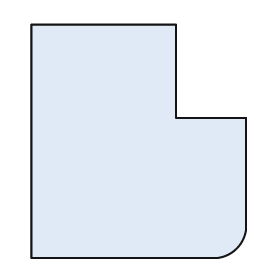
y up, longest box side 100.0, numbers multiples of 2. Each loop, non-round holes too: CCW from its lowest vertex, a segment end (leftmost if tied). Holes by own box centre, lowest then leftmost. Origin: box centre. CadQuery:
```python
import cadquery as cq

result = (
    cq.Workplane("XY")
    .moveTo(-46.0, -50.0)
    .lineTo(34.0, -50.0)
    .threePointArc((42.0, -46.0), (46.0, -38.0))
    .lineTo(46.0, 10.0)
    .lineTo(16.0, 10.0)
    .lineTo(16.0, 50.0)
    .lineTo(-46.0, 50.0)
    .close()
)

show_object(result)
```